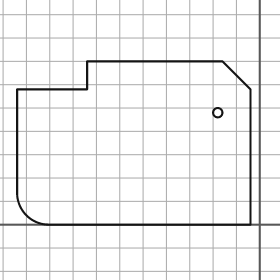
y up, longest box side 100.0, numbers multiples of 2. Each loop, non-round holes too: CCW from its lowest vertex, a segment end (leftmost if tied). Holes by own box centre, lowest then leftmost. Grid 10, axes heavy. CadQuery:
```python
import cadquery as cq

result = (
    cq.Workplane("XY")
    .moveTo(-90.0, 0.0)
    .lineTo(-4.0, 0.0)
    .lineTo(-4.0, 58.0)
    .lineTo(-16.0, 70.0)
    .lineTo(-74.0, 70.0)
    .lineTo(-74.0, 58.0)
    .lineTo(-104.0, 58.0)
    .lineTo(-104.0, 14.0)
    .threePointArc((-100.0, 4.0), (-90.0, 0.0))
    .close()
    .moveTo(-18.0, 48.0)
    .circle(2.0)
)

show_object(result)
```